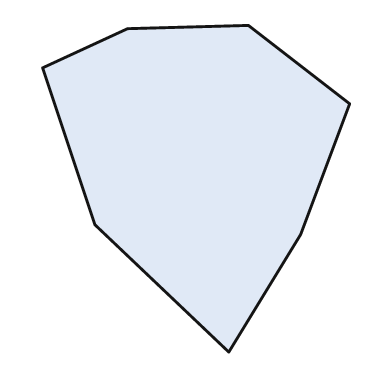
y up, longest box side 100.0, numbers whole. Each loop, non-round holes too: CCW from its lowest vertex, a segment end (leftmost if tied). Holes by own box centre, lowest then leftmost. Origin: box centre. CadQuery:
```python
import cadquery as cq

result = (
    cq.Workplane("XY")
    .moveTo(10.0, -50.0)
    .lineTo(32.0, -14.0)
    .lineTo(47.0, 26.0)
    .lineTo(16.0, 50.0)
    .lineTo(-21.0, 49.0)
    .lineTo(-47.0, 37.0)
    .lineTo(-31.0, -11.0)
    .close()
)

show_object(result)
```